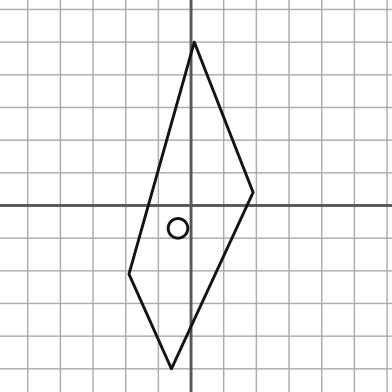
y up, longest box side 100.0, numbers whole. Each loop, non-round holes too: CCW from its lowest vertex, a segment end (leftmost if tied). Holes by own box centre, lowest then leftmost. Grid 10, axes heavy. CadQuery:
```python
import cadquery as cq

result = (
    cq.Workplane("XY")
    .moveTo(-6.0, -50.0)
    .lineTo(19.0, 4.0)
    .lineTo(1.0, 50.0)
    .lineTo(-19.0, -21.0)
    .close()
    .moveTo(-4.0, -7.0)
    .circle(3.0)
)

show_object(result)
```